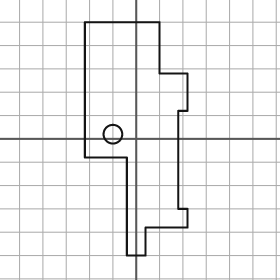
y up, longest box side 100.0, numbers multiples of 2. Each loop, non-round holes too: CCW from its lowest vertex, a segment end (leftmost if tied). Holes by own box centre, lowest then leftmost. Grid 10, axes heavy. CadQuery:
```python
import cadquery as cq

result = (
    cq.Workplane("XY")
    .moveTo(-4.0, -50.0)
    .lineTo(4.0, -50.0)
    .lineTo(4.0, -38.0)
    .lineTo(22.0, -38.0)
    .lineTo(22.0, -30.0)
    .lineTo(18.0, -30.0)
    .lineTo(18.0, 12.0)
    .lineTo(22.0, 12.0)
    .lineTo(22.0, 28.0)
    .lineTo(10.0, 28.0)
    .lineTo(10.0, 50.0)
    .lineTo(-22.0, 50.0)
    .lineTo(-22.0, -8.0)
    .lineTo(-4.0, -8.0)
    .close()
    .moveTo(-10.0, 2.0)
    .circle(4.0)
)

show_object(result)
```